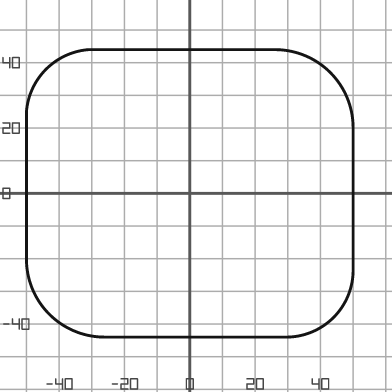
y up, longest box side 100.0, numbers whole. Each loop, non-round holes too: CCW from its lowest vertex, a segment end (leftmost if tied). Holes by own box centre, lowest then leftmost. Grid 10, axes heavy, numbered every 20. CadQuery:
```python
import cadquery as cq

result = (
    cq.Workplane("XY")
    .moveTo(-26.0, -44.0)
    .lineTo(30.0, -44.0)
    .threePointArc((44.0, -38.0), (50.0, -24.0))
    .lineTo(50.0, 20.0)
    .threePointArc((43.0, 37.0), (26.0, 44.0))
    .lineTo(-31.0, 44.0)
    .threePointArc((-44.0, 38.0), (-50.0, 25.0))
    .lineTo(-50.0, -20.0)
    .threePointArc((-43.0, -37.0), (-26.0, -44.0))
    .close()
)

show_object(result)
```